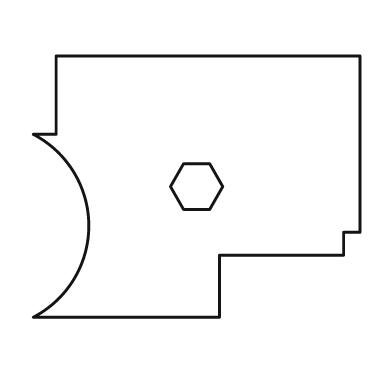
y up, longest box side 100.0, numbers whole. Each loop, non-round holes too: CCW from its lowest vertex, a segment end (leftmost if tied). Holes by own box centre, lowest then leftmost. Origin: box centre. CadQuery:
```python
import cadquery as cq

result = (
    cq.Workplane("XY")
    .moveTo(-50.0, -40.0)
    .lineTo(7.0, -40.0)
    .lineTo(7.0, -21.0)
    .lineTo(45.0, -21.0)
    .lineTo(45.0, -14.0)
    .lineTo(50.0, -14.0)
    .lineTo(50.0, 40.0)
    .lineTo(-43.0, 40.0)
    .lineTo(-43.0, 16.0)
    .lineTo(-50.0, 16.0)
    .threePointArc((-33.0, -12.0), (-50.0, -40.0))
    .close()
    .moveTo(-4.0, -7.0)
    .lineTo(4.0, -7.0)
    .lineTo(8.0, 0.0)
    .lineTo(4.0, 7.0)
    .lineTo(-4.0, 7.0)
    .lineTo(-8.0, 0.0)
    .close()
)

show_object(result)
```